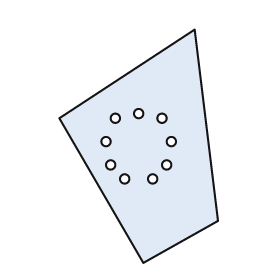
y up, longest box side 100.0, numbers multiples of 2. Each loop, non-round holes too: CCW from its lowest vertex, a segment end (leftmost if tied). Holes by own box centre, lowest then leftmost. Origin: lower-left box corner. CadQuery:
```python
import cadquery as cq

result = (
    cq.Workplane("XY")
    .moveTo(36.0, 0.0)
    .lineTo(68.0, 18.0)
    .lineTo(58.0, 100.0)
    .lineTo(0.0, 62.0)
    .close()
    .moveTo(28.0, 36.0)
    .circle(2.0)
    .moveTo(40.0, 36.0)
    .circle(2.0)
    .moveTo(22.0, 42.0)
    .circle(2.0)
    .moveTo(46.0, 42.0)
    .circle(2.0)
    .moveTo(20.0, 52.0)
    .circle(2.0)
    .moveTo(48.0, 52.0)
    .circle(2.0)
    .moveTo(24.0, 62.0)
    .circle(2.0)
    .moveTo(44.0, 62.0)
    .circle(2.0)
    .moveTo(34.0, 64.0)
    .circle(2.0)
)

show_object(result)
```